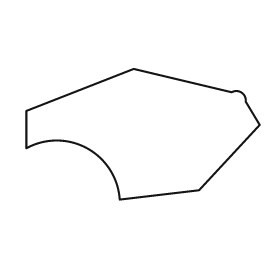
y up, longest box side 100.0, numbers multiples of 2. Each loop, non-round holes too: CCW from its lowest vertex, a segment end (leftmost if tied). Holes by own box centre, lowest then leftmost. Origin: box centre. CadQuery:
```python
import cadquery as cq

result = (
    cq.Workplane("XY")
    .moveTo(-10.0, -28.0)
    .lineTo(24.0, -24.0)
    .lineTo(50.0, 4.0)
    .lineTo(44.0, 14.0)
    .threePointArc((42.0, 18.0), (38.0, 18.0))
    .lineTo(-4.0, 28.0)
    .lineTo(-50.0, 10.0)
    .lineTo(-50.0, -6.0)
    .threePointArc((-24.0, -6.0), (-10.0, -28.0))
    .close()
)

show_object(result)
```